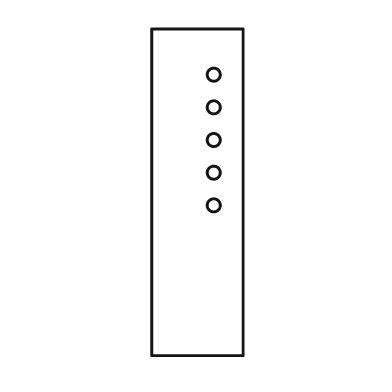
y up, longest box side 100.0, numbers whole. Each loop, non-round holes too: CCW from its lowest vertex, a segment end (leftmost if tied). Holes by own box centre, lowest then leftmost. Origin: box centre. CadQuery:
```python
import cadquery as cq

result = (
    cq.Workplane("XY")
    .moveTo(-14.0, -50.0)
    .lineTo(14.0, -50.0)
    .lineTo(14.0, 50.0)
    .lineTo(-14.0, 50.0)
    .close()
    .moveTo(5.0, -4.0)
    .circle(2.0)
    .moveTo(5.0, 6.0)
    .circle(2.0)
    .moveTo(5.0, 16.0)
    .circle(2.0)
    .moveTo(5.0, 26.0)
    .circle(2.0)
    .moveTo(5.0, 36.0)
    .circle(2.0)
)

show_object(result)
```